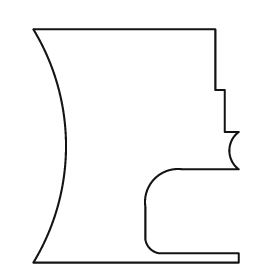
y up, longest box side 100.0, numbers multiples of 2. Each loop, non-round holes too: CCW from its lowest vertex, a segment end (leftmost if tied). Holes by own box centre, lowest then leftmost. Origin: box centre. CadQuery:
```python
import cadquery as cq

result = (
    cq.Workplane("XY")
    .moveTo(-44.0, -50.0)
    .lineTo(44.0, -50.0)
    .lineTo(44.0, -46.0)
    .lineTo(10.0, -46.0)
    .threePointArc((6.0, -44.0), (4.0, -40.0))
    .lineTo(4.0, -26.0)
    .threePointArc((8.0, -14.0), (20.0, -10.0))
    .lineTo(44.0, -10.0)
    .threePointArc((40.0, -2.0), (44.0, 6.0))
    .lineTo(38.0, 6.0)
    .lineTo(38.0, 24.0)
    .lineTo(34.0, 24.0)
    .lineTo(34.0, 50.0)
    .lineTo(-44.0, 50.0)
    .threePointArc((-30.0, 0.0), (-44.0, -50.0))
    .close()
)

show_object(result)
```